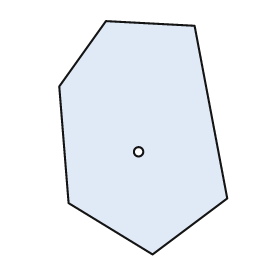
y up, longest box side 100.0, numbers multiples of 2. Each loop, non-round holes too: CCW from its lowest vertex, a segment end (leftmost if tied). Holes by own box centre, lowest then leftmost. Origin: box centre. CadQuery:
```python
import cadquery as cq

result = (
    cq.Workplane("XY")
    .moveTo(4.0, -50.0)
    .lineTo(36.0, -26.0)
    .lineTo(22.0, 48.0)
    .lineTo(-16.0, 50.0)
    .lineTo(-36.0, 22.0)
    .lineTo(-32.0, -28.0)
    .close()
    .moveTo(-2.0, -6.0)
    .circle(2.0)
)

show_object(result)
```